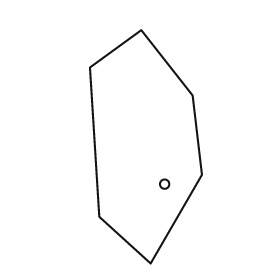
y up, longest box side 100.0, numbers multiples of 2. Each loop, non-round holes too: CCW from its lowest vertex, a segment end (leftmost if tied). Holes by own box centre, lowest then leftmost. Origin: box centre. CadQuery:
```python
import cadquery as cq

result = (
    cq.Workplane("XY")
    .moveTo(2.0, -50.0)
    .lineTo(24.0, -12.0)
    .lineTo(20.0, 22.0)
    .lineTo(-2.0, 50.0)
    .lineTo(-24.0, 34.0)
    .lineTo(-20.0, -30.0)
    .close()
    .moveTo(8.0, -16.0)
    .circle(2.0)
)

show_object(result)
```